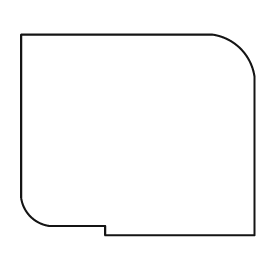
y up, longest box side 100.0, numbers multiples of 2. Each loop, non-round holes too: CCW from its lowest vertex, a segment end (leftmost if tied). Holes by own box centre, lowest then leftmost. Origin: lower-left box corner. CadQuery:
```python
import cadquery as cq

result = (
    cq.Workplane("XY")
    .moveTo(36.0, 0.0)
    .lineTo(100.0, 0.0)
    .lineTo(100.0, 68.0)
    .threePointArc((94.0, 80.0), (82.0, 86.0))
    .lineTo(0.0, 86.0)
    .lineTo(0.0, 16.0)
    .threePointArc((4.0, 8.0), (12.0, 4.0))
    .lineTo(36.0, 4.0)
    .close()
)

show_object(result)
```